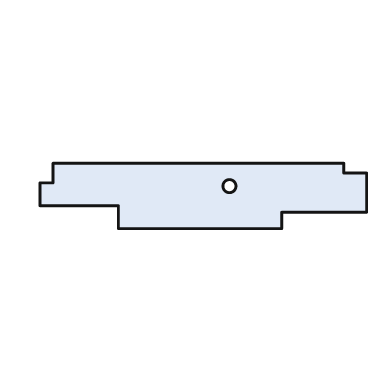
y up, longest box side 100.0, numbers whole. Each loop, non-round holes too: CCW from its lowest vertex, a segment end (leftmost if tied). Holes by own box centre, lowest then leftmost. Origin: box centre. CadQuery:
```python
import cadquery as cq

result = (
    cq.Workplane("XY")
    .moveTo(-26.0, -10.0)
    .lineTo(24.0, -10.0)
    .lineTo(24.0, -5.0)
    .lineTo(50.0, -5.0)
    .lineTo(50.0, 7.0)
    .lineTo(43.0, 7.0)
    .lineTo(43.0, 10.0)
    .lineTo(-46.0, 10.0)
    .lineTo(-46.0, 4.0)
    .lineTo(-50.0, 4.0)
    .lineTo(-50.0, -3.0)
    .lineTo(-26.0, -3.0)
    .close()
    .moveTo(8.0, 3.0)
    .circle(2.0)
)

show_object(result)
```